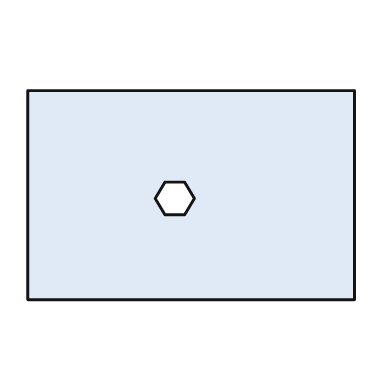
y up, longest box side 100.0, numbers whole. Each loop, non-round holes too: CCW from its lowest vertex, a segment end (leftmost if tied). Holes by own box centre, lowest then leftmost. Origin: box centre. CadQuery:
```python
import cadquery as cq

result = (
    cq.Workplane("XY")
    .moveTo(-50.0, -32.0)
    .lineTo(50.0, -32.0)
    .lineTo(50.0, 32.0)
    .lineTo(-50.0, 32.0)
    .close()
    .moveTo(-8.0, -6.0)
    .lineTo(-2.0, -6.0)
    .lineTo(1.0, -1.0)
    .lineTo(-2.0, 4.0)
    .lineTo(-8.0, 4.0)
    .lineTo(-11.0, -1.0)
    .close()
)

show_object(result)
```